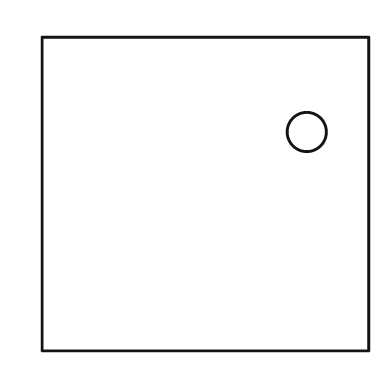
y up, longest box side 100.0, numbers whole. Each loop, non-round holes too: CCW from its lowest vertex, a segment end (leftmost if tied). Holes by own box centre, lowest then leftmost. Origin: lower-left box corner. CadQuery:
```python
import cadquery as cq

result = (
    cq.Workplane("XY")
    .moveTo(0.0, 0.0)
    .lineTo(100.0, 0.0)
    .lineTo(100.0, 96.0)
    .lineTo(0.0, 96.0)
    .close()
    .moveTo(81.0, 67.0)
    .circle(6.0)
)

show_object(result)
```